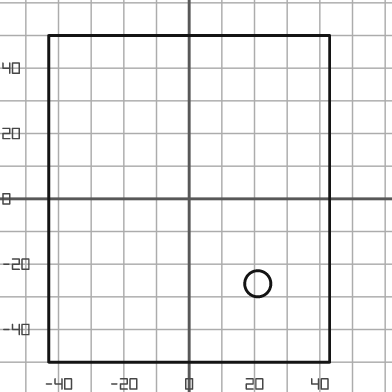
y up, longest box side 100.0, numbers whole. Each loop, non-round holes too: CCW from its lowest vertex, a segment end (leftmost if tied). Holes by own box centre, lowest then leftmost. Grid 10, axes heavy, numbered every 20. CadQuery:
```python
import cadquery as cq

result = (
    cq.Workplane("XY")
    .moveTo(-43.0, -50.0)
    .lineTo(43.0, -50.0)
    .lineTo(43.0, 50.0)
    .lineTo(-43.0, 50.0)
    .close()
    .moveTo(21.0, -26.0)
    .circle(4.0)
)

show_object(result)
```